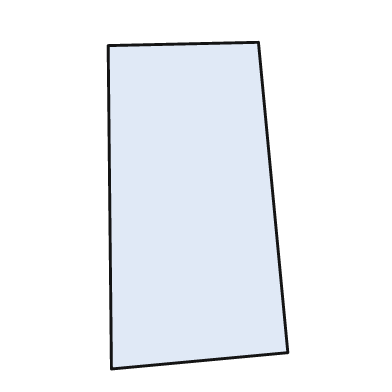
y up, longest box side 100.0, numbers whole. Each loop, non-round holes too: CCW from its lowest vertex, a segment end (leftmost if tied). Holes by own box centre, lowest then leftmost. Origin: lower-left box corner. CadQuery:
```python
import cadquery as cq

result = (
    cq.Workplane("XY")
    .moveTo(1.0, 0.0)
    .lineTo(55.0, 5.0)
    .lineTo(46.0, 100.0)
    .lineTo(0.0, 99.0)
    .close()
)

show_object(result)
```